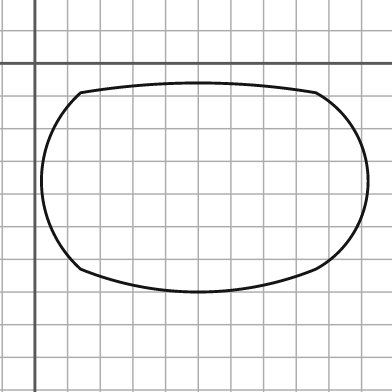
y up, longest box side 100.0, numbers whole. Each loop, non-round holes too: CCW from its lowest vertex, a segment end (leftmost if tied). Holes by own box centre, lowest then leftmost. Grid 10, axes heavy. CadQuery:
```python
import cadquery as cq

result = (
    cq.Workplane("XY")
    .moveTo(14.0, -63.0)
    .threePointArc((50.0, -70.0), (86.0, -63.0))
    .threePointArc((102.0, -36.0), (86.0, -9.0))
    .threePointArc((50.0, -6.0), (14.0, -9.0))
    .threePointArc((2.0, -36.0), (14.0, -63.0))
    .close()
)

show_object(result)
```